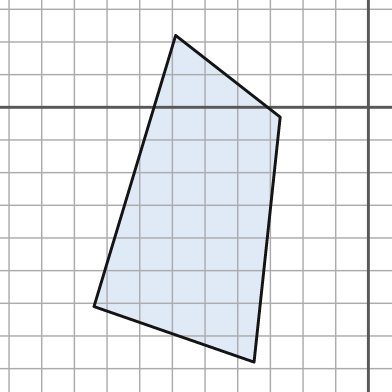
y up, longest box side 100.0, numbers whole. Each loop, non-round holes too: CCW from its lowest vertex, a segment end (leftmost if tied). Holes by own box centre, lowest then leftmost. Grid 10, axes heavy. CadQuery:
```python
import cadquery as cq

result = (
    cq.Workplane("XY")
    .moveTo(-35.0, -78.0)
    .lineTo(-27.0, -3.0)
    .lineTo(-59.0, 22.0)
    .lineTo(-84.0, -61.0)
    .close()
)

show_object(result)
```